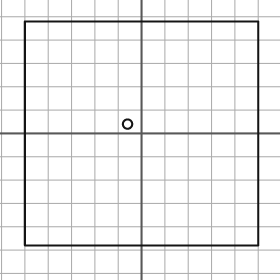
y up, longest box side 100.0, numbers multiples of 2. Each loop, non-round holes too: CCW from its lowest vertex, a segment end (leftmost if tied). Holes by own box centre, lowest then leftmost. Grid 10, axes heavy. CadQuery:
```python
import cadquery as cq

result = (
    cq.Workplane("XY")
    .moveTo(-50.0, -48.0)
    .lineTo(50.0, -48.0)
    .lineTo(50.0, 48.0)
    .lineTo(-50.0, 48.0)
    .close()
    .moveTo(-6.0, 4.0)
    .circle(2.0)
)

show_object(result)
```